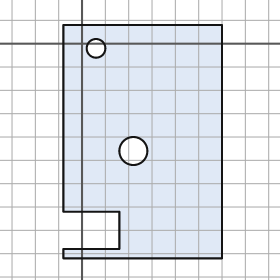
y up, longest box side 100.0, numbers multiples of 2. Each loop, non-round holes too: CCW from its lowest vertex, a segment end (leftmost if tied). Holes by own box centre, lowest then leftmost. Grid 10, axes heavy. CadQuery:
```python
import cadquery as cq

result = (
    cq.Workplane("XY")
    .moveTo(-8.0, -92.0)
    .lineTo(60.0, -92.0)
    .lineTo(60.0, 8.0)
    .lineTo(-8.0, 8.0)
    .lineTo(-8.0, -72.0)
    .lineTo(16.0, -72.0)
    .lineTo(16.0, -88.0)
    .lineTo(-8.0, -88.0)
    .close()
    .moveTo(22.0, -46.0)
    .circle(6.0)
    .moveTo(6.0, -2.0)
    .circle(4.0)
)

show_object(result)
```